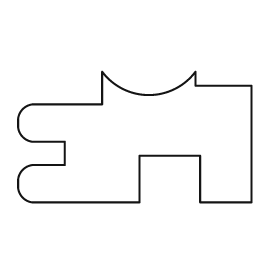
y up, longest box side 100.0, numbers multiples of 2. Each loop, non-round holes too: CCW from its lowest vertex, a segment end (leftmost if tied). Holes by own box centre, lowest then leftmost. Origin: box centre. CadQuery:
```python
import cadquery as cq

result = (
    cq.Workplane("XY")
    .moveTo(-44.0, -28.0)
    .lineTo(2.0, -28.0)
    .lineTo(2.0, -8.0)
    .lineTo(28.0, -8.0)
    .lineTo(28.0, -28.0)
    .lineTo(50.0, -28.0)
    .lineTo(50.0, 22.0)
    .lineTo(26.0, 22.0)
    .lineTo(26.0, 28.0)
    .threePointArc((6.0, 18.0), (-14.0, 28.0))
    .lineTo(-14.0, 14.0)
    .lineTo(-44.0, 14.0)
    .threePointArc((-48.0, 12.0), (-50.0, 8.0))
    .lineTo(-50.0, 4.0)
    .threePointArc((-48.0, 0.0), (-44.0, -2.0))
    .lineTo(-30.0, -2.0)
    .lineTo(-30.0, -12.0)
    .lineTo(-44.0, -12.0)
    .threePointArc((-48.0, -14.0), (-50.0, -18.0))
    .lineTo(-50.0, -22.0)
    .threePointArc((-48.0, -26.0), (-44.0, -28.0))
    .close()
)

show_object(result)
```